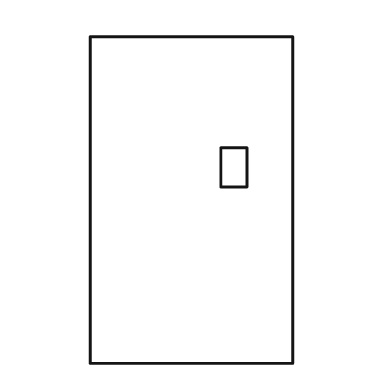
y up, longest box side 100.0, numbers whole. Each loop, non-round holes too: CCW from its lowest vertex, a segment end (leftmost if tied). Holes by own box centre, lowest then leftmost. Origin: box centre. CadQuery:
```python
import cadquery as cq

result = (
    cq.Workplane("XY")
    .moveTo(-31.0, -50.0)
    .lineTo(31.0, -50.0)
    .lineTo(31.0, 50.0)
    .lineTo(-31.0, 50.0)
    .close()
    .moveTo(9.0, 4.0)
    .lineTo(17.0, 4.0)
    .lineTo(17.0, 16.0)
    .lineTo(9.0, 16.0)
    .close()
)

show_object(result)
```